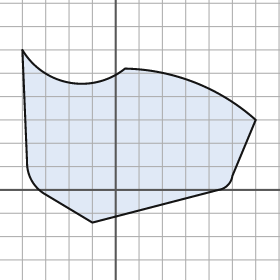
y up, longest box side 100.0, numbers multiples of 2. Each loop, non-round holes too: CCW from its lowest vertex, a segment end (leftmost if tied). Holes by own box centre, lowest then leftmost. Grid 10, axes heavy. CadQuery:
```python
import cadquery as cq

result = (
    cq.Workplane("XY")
    .moveTo(-10.0, -14.0)
    .lineTo(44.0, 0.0)
    .threePointArc((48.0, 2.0), (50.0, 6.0))
    .lineTo(60.0, 30.0)
    .threePointArc((34.0, 46.0), (4.0, 52.0))
    .threePointArc((-20.0, 46.0), (-40.0, 60.0))
    .lineTo(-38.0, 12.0)
    .threePointArc((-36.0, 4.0), (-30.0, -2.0))
    .close()
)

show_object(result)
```